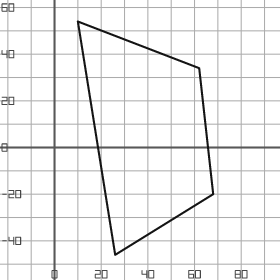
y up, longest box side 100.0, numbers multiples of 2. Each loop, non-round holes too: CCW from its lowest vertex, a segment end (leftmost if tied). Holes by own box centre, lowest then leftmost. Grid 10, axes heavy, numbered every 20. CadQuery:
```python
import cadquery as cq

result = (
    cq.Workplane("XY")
    .moveTo(26.0, -46.0)
    .lineTo(68.0, -20.0)
    .lineTo(62.0, 34.0)
    .lineTo(10.0, 54.0)
    .close()
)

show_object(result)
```